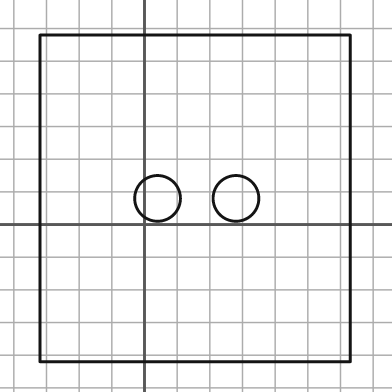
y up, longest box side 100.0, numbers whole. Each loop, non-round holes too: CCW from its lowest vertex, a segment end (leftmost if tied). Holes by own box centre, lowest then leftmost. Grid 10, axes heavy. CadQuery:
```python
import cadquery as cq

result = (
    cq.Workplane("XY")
    .moveTo(-32.0, -42.0)
    .lineTo(63.0, -42.0)
    .lineTo(63.0, 58.0)
    .lineTo(-32.0, 58.0)
    .close()
    .moveTo(4.0, 8.0)
    .circle(7.0)
    .moveTo(28.0, 8.0)
    .circle(7.0)
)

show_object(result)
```